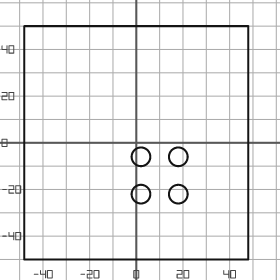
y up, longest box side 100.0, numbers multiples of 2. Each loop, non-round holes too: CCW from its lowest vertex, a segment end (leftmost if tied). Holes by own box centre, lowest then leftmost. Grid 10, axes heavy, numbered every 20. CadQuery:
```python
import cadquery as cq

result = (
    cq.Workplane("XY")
    .moveTo(-48.0, -50.0)
    .lineTo(48.0, -50.0)
    .lineTo(48.0, 50.0)
    .lineTo(-48.0, 50.0)
    .close()
    .moveTo(2.0, -22.0)
    .circle(4.0)
    .moveTo(18.0, -22.0)
    .circle(4.0)
    .moveTo(2.0, -6.0)
    .circle(4.0)
    .moveTo(18.0, -6.0)
    .circle(4.0)
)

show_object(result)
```